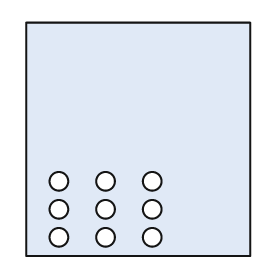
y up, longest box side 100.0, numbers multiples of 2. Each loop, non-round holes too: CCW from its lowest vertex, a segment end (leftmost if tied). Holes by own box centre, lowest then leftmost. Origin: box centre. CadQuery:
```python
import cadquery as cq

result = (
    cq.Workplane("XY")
    .moveTo(-48.0, -50.0)
    .lineTo(48.0, -50.0)
    .lineTo(48.0, 50.0)
    .lineTo(-48.0, 50.0)
    .close()
    .moveTo(-34.0, -42.0)
    .circle(4.0)
    .moveTo(-14.0, -42.0)
    .circle(4.0)
    .moveTo(6.0, -42.0)
    .circle(4.0)
    .moveTo(-34.0, -30.0)
    .circle(4.0)
    .moveTo(-14.0, -30.0)
    .circle(4.0)
    .moveTo(6.0, -30.0)
    .circle(4.0)
    .moveTo(-34.0, -18.0)
    .circle(4.0)
    .moveTo(-14.0, -18.0)
    .circle(4.0)
    .moveTo(6.0, -18.0)
    .circle(4.0)
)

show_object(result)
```